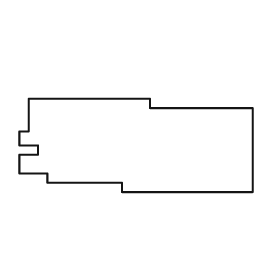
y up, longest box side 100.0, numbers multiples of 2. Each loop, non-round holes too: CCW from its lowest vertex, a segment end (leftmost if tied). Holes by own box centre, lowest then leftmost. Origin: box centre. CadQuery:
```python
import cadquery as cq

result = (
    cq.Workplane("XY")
    .moveTo(-6.0, -20.0)
    .lineTo(50.0, -20.0)
    .lineTo(50.0, 16.0)
    .lineTo(6.0, 16.0)
    .lineTo(6.0, 20.0)
    .lineTo(-46.0, 20.0)
    .lineTo(-46.0, 6.0)
    .lineTo(-50.0, 6.0)
    .lineTo(-50.0, 0.0)
    .lineTo(-42.0, 0.0)
    .lineTo(-42.0, -4.0)
    .lineTo(-50.0, -4.0)
    .lineTo(-50.0, -12.0)
    .lineTo(-38.0, -12.0)
    .lineTo(-38.0, -16.0)
    .lineTo(-6.0, -16.0)
    .close()
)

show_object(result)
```